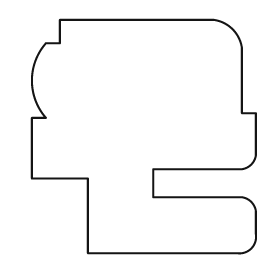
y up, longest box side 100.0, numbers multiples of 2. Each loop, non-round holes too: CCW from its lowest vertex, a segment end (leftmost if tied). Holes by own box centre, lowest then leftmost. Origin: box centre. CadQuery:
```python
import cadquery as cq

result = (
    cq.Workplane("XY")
    .moveTo(-24.0, -50.0)
    .lineTo(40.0, -50.0)
    .threePointArc((46.0, -48.0), (48.0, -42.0))
    .lineTo(48.0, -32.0)
    .threePointArc((46.0, -28.0), (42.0, -26.0))
    .lineTo(4.0, -26.0)
    .lineTo(4.0, -14.0)
    .lineTo(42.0, -14.0)
    .threePointArc((46.0, -12.0), (48.0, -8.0))
    .lineTo(48.0, 10.0)
    .lineTo(42.0, 10.0)
    .lineTo(42.0, 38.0)
    .threePointArc((38.0, 46.0), (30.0, 50.0))
    .lineTo(-36.0, 50.0)
    .lineTo(-36.0, 40.0)
    .lineTo(-42.0, 40.0)
    .threePointArc((-48.0, 24.0), (-42.0, 8.0))
    .lineTo(-48.0, 8.0)
    .lineTo(-48.0, -18.0)
    .lineTo(-24.0, -18.0)
    .close()
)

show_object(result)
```